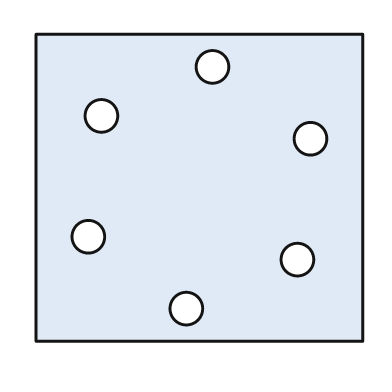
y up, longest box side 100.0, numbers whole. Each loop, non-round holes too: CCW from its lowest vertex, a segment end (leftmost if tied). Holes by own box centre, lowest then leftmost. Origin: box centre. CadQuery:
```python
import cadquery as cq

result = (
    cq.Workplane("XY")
    .moveTo(-50.0, -47.0)
    .lineTo(50.0, -47.0)
    .lineTo(50.0, 47.0)
    .lineTo(-50.0, 47.0)
    .close()
    .moveTo(-4.0, -37.0)
    .circle(5.0)
    .moveTo(30.0, -22.0)
    .circle(5.0)
    .moveTo(-34.0, -15.0)
    .circle(5.0)
    .moveTo(34.0, 15.0)
    .circle(5.0)
    .moveTo(-30.0, 22.0)
    .circle(5.0)
    .moveTo(4.0, 37.0)
    .circle(5.0)
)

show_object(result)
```